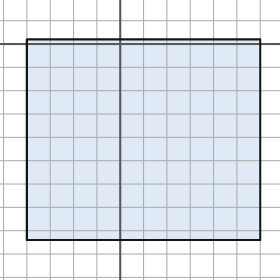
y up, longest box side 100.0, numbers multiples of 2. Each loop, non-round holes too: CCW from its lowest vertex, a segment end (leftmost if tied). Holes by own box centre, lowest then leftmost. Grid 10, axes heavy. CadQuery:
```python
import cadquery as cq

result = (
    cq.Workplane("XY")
    .moveTo(-40.0, -84.0)
    .lineTo(60.0, -84.0)
    .lineTo(60.0, 2.0)
    .lineTo(-40.0, 2.0)
    .close()
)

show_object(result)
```